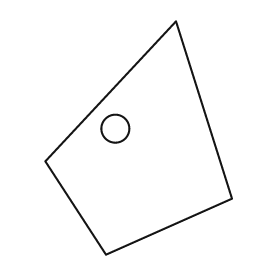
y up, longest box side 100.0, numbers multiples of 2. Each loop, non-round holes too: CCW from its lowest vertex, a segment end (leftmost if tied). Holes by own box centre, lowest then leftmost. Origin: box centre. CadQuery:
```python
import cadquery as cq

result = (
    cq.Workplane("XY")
    .moveTo(-14.0, -50.0)
    .lineTo(40.0, -26.0)
    .lineTo(16.0, 50.0)
    .lineTo(-40.0, -10.0)
    .close()
    .moveTo(-10.0, 4.0)
    .circle(6.0)
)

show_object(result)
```